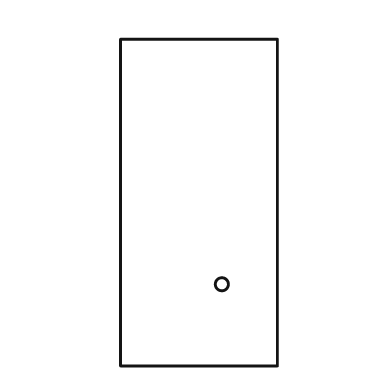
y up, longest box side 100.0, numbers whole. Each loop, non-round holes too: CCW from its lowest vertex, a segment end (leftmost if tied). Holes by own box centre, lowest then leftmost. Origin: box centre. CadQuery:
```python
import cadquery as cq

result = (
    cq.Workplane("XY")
    .moveTo(-24.0, -50.0)
    .lineTo(24.0, -50.0)
    .lineTo(24.0, 50.0)
    .lineTo(-24.0, 50.0)
    .close()
    .moveTo(7.0, -25.0)
    .circle(2.0)
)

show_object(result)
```